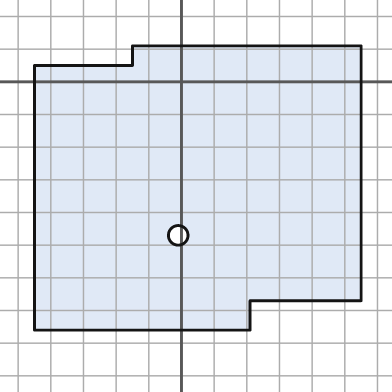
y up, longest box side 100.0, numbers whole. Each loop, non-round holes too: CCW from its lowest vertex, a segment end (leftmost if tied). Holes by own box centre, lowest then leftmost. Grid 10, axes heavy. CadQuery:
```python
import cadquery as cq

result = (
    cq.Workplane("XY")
    .moveTo(-45.0, -76.0)
    .lineTo(21.0, -76.0)
    .lineTo(21.0, -67.0)
    .lineTo(55.0, -67.0)
    .lineTo(55.0, 11.0)
    .lineTo(-15.0, 11.0)
    .lineTo(-15.0, 5.0)
    .lineTo(-45.0, 5.0)
    .close()
    .moveTo(-1.0, -47.0)
    .circle(3.0)
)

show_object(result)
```